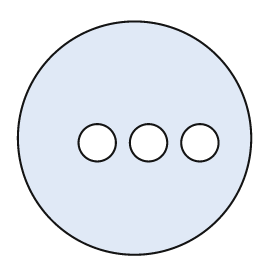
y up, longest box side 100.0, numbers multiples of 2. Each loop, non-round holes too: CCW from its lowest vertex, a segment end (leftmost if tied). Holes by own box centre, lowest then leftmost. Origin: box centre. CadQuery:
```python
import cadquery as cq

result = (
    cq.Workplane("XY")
    .moveTo(0.0, 0.0)
    .circle(50.0)
    .moveTo(-16.0, -2.0)
    .circle(8.0)
    .moveTo(6.0, -2.0)
    .circle(8.0)
    .moveTo(28.0, -2.0)
    .circle(8.0)
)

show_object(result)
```